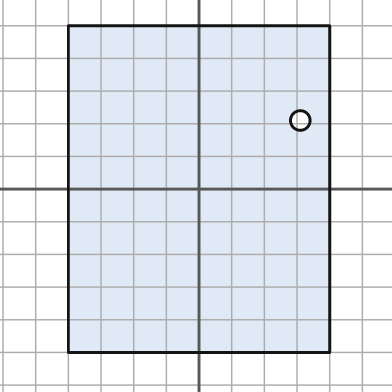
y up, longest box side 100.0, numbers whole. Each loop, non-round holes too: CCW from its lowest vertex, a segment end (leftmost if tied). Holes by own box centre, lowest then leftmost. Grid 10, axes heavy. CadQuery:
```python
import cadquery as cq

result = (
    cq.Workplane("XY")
    .moveTo(-40.0, -50.0)
    .lineTo(40.0, -50.0)
    .lineTo(40.0, 50.0)
    .lineTo(-40.0, 50.0)
    .close()
    .moveTo(31.0, 21.0)
    .circle(3.0)
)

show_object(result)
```